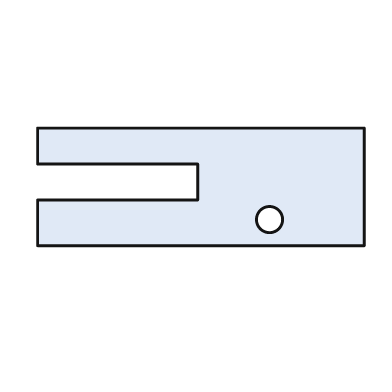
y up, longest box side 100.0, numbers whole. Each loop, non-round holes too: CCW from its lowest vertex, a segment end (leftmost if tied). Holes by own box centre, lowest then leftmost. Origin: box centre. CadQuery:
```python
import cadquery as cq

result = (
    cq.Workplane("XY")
    .moveTo(-50.0, -18.0)
    .lineTo(50.0, -18.0)
    .lineTo(50.0, 18.0)
    .lineTo(-50.0, 18.0)
    .lineTo(-50.0, 7.0)
    .lineTo(-1.0, 7.0)
    .lineTo(-1.0, -4.0)
    .lineTo(-50.0, -4.0)
    .close()
    .moveTo(21.0, -10.0)
    .circle(4.0)
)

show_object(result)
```